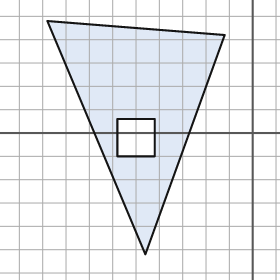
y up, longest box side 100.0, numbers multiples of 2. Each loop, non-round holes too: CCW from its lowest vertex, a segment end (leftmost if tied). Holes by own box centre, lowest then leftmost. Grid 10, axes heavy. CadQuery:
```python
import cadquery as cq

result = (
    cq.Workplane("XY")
    .moveTo(-46.0, -52.0)
    .lineTo(-12.0, 42.0)
    .lineTo(-88.0, 48.0)
    .close()
    .moveTo(-58.0, -10.0)
    .lineTo(-42.0, -10.0)
    .lineTo(-42.0, 6.0)
    .lineTo(-58.0, 6.0)
    .close()
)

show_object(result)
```